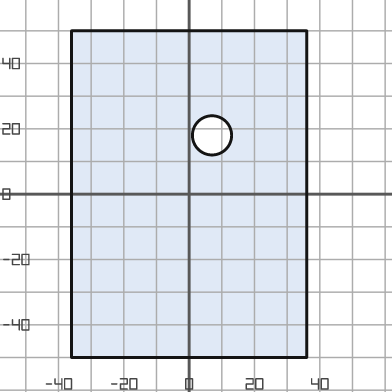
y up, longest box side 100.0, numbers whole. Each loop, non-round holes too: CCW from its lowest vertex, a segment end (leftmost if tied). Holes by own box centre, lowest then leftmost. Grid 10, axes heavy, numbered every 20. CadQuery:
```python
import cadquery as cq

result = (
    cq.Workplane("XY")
    .moveTo(-36.0, -50.0)
    .lineTo(36.0, -50.0)
    .lineTo(36.0, 50.0)
    .lineTo(-36.0, 50.0)
    .close()
    .moveTo(7.0, 18.0)
    .circle(6.0)
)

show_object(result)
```